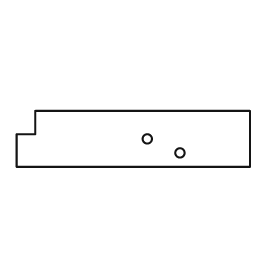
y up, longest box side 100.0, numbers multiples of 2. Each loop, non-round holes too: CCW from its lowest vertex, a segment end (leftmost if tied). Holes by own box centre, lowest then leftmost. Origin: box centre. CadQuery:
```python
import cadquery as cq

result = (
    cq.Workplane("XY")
    .moveTo(-50.0, -12.0)
    .lineTo(50.0, -12.0)
    .lineTo(50.0, 12.0)
    .lineTo(-42.0, 12.0)
    .lineTo(-42.0, 2.0)
    .lineTo(-50.0, 2.0)
    .close()
    .moveTo(20.0, -6.0)
    .circle(2.0)
    .moveTo(6.0, 0.0)
    .circle(2.0)
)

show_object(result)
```